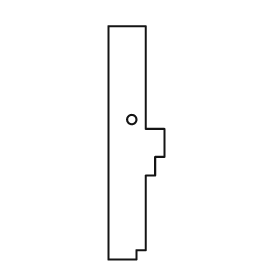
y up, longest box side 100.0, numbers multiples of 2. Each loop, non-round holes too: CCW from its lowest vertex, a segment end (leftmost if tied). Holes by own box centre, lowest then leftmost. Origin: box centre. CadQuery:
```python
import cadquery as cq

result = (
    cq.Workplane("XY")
    .moveTo(-12.0, -50.0)
    .lineTo(0.0, -50.0)
    .lineTo(0.0, -46.0)
    .lineTo(4.0, -46.0)
    .lineTo(4.0, -14.0)
    .lineTo(8.0, -14.0)
    .lineTo(8.0, -6.0)
    .lineTo(12.0, -6.0)
    .lineTo(12.0, 6.0)
    .lineTo(4.0, 6.0)
    .lineTo(4.0, 50.0)
    .lineTo(-12.0, 50.0)
    .close()
    .moveTo(-2.0, 10.0)
    .circle(2.0)
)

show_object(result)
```